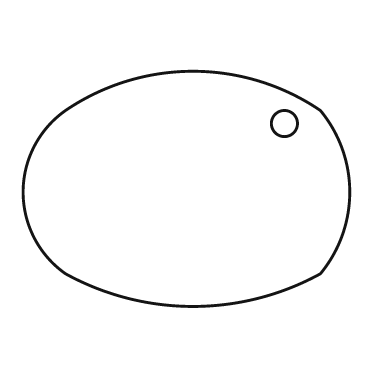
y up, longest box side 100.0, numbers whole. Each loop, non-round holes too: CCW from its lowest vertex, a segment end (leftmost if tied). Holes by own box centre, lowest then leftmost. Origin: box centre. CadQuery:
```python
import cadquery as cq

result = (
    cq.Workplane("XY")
    .moveTo(-37.0, -26.0)
    .threePointArc((2.0, -36.0), (41.0, -26.0))
    .threePointArc((50.0, -1.0), (41.0, 24.0))
    .threePointArc((2.0, 36.0), (-37.0, 24.0))
    .threePointArc((-50.0, -1.0), (-37.0, -26.0))
    .close()
    .moveTo(30.0, 20.0)
    .circle(4.0)
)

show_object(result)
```